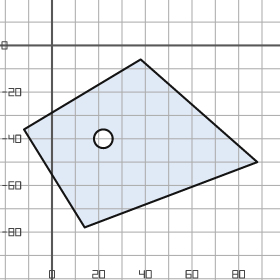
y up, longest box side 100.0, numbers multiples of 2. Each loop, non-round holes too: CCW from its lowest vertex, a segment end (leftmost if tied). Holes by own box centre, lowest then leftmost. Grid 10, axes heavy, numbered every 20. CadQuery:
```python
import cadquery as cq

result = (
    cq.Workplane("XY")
    .moveTo(14.0, -78.0)
    .lineTo(88.0, -50.0)
    .lineTo(38.0, -6.0)
    .lineTo(-12.0, -36.0)
    .close()
    .moveTo(22.0, -40.0)
    .circle(4.0)
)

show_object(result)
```